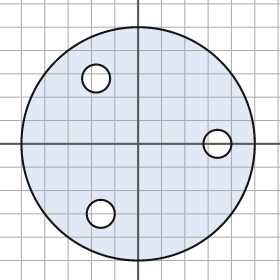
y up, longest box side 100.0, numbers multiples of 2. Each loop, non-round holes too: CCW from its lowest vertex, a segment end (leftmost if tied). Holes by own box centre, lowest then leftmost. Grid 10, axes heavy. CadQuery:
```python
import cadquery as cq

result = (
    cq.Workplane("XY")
    .moveTo(0.0, 0.0)
    .circle(50.0)
    .moveTo(-16.0, -30.0)
    .circle(6.0)
    .moveTo(34.0, 0.0)
    .circle(6.0)
    .moveTo(-18.0, 28.0)
    .circle(6.0)
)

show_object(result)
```